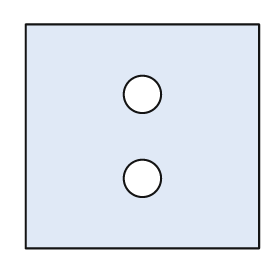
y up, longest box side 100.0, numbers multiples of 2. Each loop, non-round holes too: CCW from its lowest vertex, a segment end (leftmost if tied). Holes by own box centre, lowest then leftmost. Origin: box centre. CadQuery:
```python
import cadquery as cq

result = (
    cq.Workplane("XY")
    .moveTo(-50.0, -48.0)
    .lineTo(50.0, -48.0)
    .lineTo(50.0, 48.0)
    .lineTo(-50.0, 48.0)
    .close()
    .moveTo(0.0, -18.0)
    .circle(8.0)
    .moveTo(0.0, 18.0)
    .circle(8.0)
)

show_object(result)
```